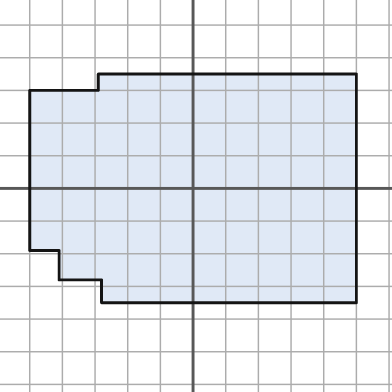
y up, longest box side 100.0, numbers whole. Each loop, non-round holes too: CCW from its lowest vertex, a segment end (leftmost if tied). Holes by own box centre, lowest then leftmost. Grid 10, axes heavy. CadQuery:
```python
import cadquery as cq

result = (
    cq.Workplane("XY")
    .moveTo(-28.0, -35.0)
    .lineTo(50.0, -35.0)
    .lineTo(50.0, 35.0)
    .lineTo(-29.0, 35.0)
    .lineTo(-29.0, 30.0)
    .lineTo(-50.0, 30.0)
    .lineTo(-50.0, -19.0)
    .lineTo(-41.0, -19.0)
    .lineTo(-41.0, -28.0)
    .lineTo(-28.0, -28.0)
    .close()
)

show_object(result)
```